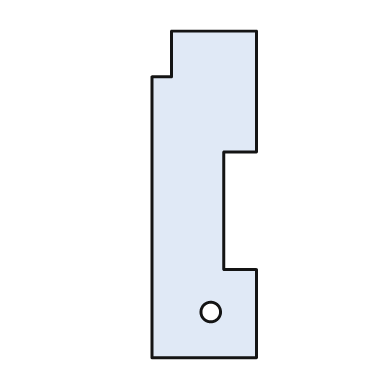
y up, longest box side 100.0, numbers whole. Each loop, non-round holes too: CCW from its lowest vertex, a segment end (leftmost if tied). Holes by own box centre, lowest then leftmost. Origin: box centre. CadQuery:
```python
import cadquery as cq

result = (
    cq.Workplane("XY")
    .moveTo(-16.0, -50.0)
    .lineTo(16.0, -50.0)
    .lineTo(16.0, -23.0)
    .lineTo(6.0, -23.0)
    .lineTo(6.0, 13.0)
    .lineTo(16.0, 13.0)
    .lineTo(16.0, 50.0)
    .lineTo(-10.0, 50.0)
    .lineTo(-10.0, 36.0)
    .lineTo(-16.0, 36.0)
    .close()
    .moveTo(2.0, -36.0)
    .circle(3.0)
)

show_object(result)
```